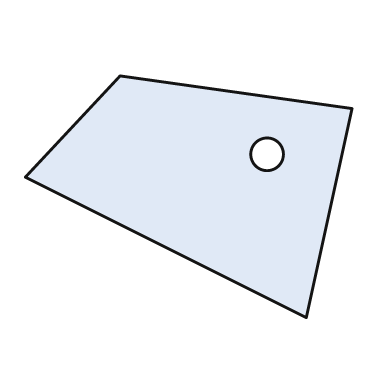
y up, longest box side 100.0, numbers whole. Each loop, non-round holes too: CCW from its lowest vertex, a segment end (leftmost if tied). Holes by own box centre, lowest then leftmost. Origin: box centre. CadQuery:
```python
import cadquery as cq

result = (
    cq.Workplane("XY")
    .moveTo(36.0, -37.0)
    .lineTo(50.0, 27.0)
    .lineTo(-21.0, 37.0)
    .lineTo(-50.0, 6.0)
    .close()
    .moveTo(24.0, 13.0)
    .circle(5.0)
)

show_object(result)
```